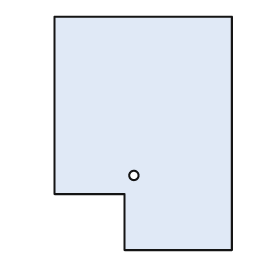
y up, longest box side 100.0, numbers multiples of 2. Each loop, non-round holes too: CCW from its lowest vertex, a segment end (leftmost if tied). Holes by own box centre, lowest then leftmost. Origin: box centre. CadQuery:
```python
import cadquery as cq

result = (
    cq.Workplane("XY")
    .moveTo(-8.0, -50.0)
    .lineTo(38.0, -50.0)
    .lineTo(38.0, 50.0)
    .lineTo(-38.0, 50.0)
    .lineTo(-38.0, -26.0)
    .lineTo(-8.0, -26.0)
    .close()
    .moveTo(-4.0, -18.0)
    .circle(2.0)
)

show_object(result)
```